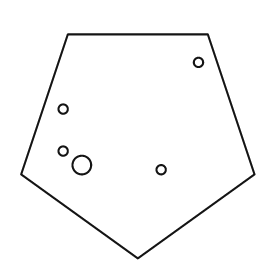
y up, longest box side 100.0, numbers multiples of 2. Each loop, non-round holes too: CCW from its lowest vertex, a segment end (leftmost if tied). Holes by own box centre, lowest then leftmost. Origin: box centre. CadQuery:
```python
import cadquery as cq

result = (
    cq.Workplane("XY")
    .moveTo(0.0, -48.0)
    .lineTo(50.0, -12.0)
    .lineTo(30.0, 48.0)
    .lineTo(-30.0, 48.0)
    .lineTo(-50.0, -12.0)
    .close()
    .moveTo(10.0, -10.0)
    .circle(2.0)
    .moveTo(-24.0, -8.0)
    .circle(4.0)
    .moveTo(-32.0, -2.0)
    .circle(2.0)
    .moveTo(-32.0, 16.0)
    .circle(2.0)
    .moveTo(26.0, 36.0)
    .circle(2.0)
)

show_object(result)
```